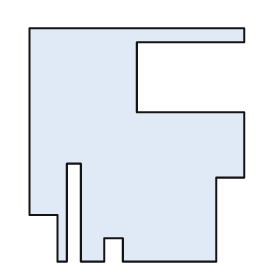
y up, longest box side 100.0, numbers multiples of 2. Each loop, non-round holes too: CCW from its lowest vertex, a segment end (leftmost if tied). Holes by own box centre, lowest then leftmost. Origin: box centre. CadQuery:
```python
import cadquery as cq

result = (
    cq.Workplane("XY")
    .moveTo(-34.0, -50.0)
    .lineTo(-30.0, -50.0)
    .lineTo(-30.0, -8.0)
    .lineTo(-24.0, -8.0)
    .lineTo(-24.0, -50.0)
    .lineTo(-14.0, -50.0)
    .lineTo(-14.0, -40.0)
    .lineTo(-6.0, -40.0)
    .lineTo(-6.0, -50.0)
    .lineTo(34.0, -50.0)
    .lineTo(34.0, -14.0)
    .lineTo(46.0, -14.0)
    .lineTo(46.0, 14.0)
    .lineTo(0.0, 14.0)
    .lineTo(0.0, 44.0)
    .lineTo(46.0, 44.0)
    .lineTo(46.0, 50.0)
    .lineTo(-46.0, 50.0)
    .lineTo(-46.0, -30.0)
    .lineTo(-34.0, -30.0)
    .close()
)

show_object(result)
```